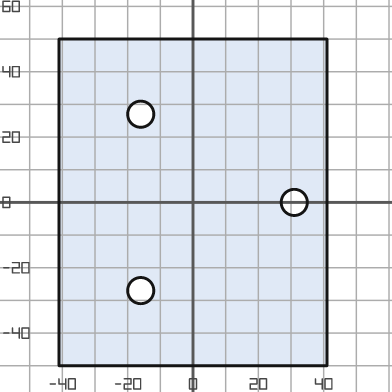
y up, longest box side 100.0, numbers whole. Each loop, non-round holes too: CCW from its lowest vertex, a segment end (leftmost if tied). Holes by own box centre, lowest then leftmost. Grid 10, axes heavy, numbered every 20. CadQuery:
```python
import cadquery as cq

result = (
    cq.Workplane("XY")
    .moveTo(-41.0, -50.0)
    .lineTo(41.0, -50.0)
    .lineTo(41.0, 50.0)
    .lineTo(-41.0, 50.0)
    .close()
    .moveTo(-16.0, -27.0)
    .circle(4.0)
    .moveTo(31.0, 0.0)
    .circle(4.0)
    .moveTo(-16.0, 27.0)
    .circle(4.0)
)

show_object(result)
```